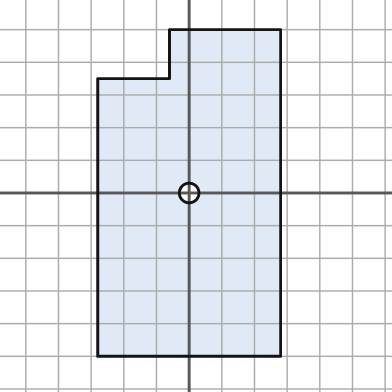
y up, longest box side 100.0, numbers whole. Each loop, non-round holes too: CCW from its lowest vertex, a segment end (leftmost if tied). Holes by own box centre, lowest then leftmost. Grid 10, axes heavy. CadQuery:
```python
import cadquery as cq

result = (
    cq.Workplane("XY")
    .moveTo(-28.0, -50.0)
    .lineTo(28.0, -50.0)
    .lineTo(28.0, 50.0)
    .lineTo(-6.0, 50.0)
    .lineTo(-6.0, 35.0)
    .lineTo(-28.0, 35.0)
    .close()
    .moveTo(0.0, 0.0)
    .circle(3.0)
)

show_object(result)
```